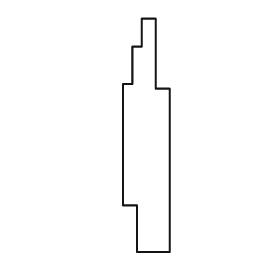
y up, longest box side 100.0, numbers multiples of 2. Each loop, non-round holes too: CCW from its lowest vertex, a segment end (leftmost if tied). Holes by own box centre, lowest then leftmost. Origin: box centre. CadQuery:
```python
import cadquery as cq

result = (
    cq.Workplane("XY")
    .moveTo(-4.0, -50.0)
    .lineTo(10.0, -50.0)
    .lineTo(10.0, 20.0)
    .lineTo(4.0, 20.0)
    .lineTo(4.0, 50.0)
    .lineTo(-2.0, 50.0)
    .lineTo(-2.0, 38.0)
    .lineTo(-6.0, 38.0)
    .lineTo(-6.0, 22.0)
    .lineTo(-10.0, 22.0)
    .lineTo(-10.0, -30.0)
    .lineTo(-4.0, -30.0)
    .close()
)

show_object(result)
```